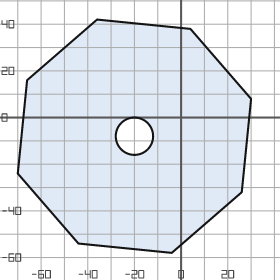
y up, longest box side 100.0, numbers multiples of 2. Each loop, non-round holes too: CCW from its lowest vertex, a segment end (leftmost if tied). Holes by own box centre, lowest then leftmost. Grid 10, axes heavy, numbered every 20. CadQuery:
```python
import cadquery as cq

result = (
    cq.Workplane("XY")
    .moveTo(-4.0, -58.0)
    .lineTo(26.0, -32.0)
    .lineTo(30.0, 8.0)
    .lineTo(4.0, 38.0)
    .lineTo(-36.0, 42.0)
    .lineTo(-66.0, 16.0)
    .lineTo(-70.0, -24.0)
    .lineTo(-44.0, -54.0)
    .close()
    .moveTo(-20.0, -8.0)
    .circle(8.0)
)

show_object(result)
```